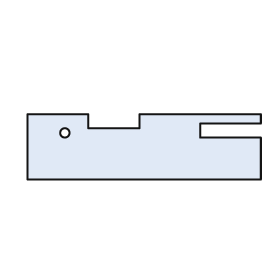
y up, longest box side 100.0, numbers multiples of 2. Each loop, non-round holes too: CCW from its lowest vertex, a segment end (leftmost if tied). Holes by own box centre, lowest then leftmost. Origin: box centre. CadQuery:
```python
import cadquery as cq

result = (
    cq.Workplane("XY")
    .moveTo(-50.0, -14.0)
    .lineTo(50.0, -14.0)
    .lineTo(50.0, 4.0)
    .lineTo(24.0, 4.0)
    .lineTo(24.0, 10.0)
    .lineTo(50.0, 10.0)
    .lineTo(50.0, 14.0)
    .lineTo(-2.0, 14.0)
    .lineTo(-2.0, 8.0)
    .lineTo(-24.0, 8.0)
    .lineTo(-24.0, 14.0)
    .lineTo(-50.0, 14.0)
    .close()
    .moveTo(-34.0, 6.0)
    .circle(2.0)
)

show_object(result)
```